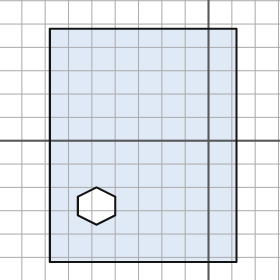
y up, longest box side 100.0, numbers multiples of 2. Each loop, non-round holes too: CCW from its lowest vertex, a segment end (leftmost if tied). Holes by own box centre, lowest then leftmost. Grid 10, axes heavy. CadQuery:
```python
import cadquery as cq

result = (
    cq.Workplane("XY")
    .moveTo(-68.0, -52.0)
    .lineTo(12.0, -52.0)
    .lineTo(12.0, 48.0)
    .lineTo(-68.0, 48.0)
    .close()
    .moveTo(-48.0, -36.0)
    .lineTo(-40.0, -32.0)
    .lineTo(-40.0, -24.0)
    .lineTo(-48.0, -20.0)
    .lineTo(-56.0, -24.0)
    .lineTo(-56.0, -32.0)
    .close()
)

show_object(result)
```